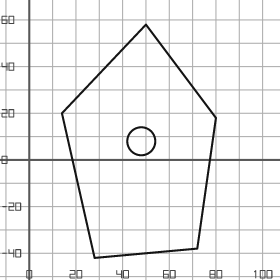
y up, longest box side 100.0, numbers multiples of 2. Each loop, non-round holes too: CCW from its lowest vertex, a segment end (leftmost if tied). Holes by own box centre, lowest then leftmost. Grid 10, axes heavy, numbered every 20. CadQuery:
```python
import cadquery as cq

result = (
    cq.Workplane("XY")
    .moveTo(28.0, -42.0)
    .lineTo(72.0, -38.0)
    .lineTo(80.0, 18.0)
    .lineTo(50.0, 58.0)
    .lineTo(14.0, 20.0)
    .close()
    .moveTo(48.0, 8.0)
    .circle(6.0)
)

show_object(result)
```